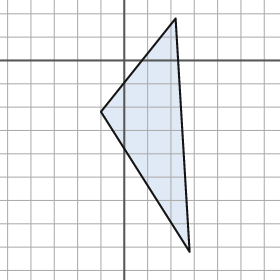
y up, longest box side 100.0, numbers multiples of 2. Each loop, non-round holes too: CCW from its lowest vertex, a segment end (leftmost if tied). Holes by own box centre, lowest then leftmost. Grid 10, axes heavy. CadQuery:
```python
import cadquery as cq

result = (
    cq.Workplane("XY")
    .moveTo(28.0, -82.0)
    .lineTo(22.0, 18.0)
    .lineTo(-10.0, -22.0)
    .close()
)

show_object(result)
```